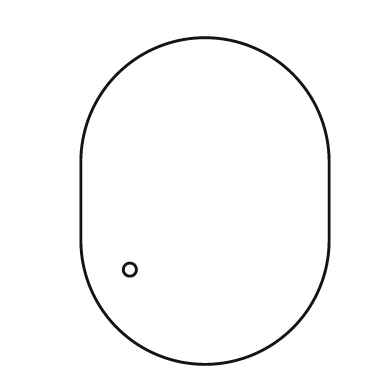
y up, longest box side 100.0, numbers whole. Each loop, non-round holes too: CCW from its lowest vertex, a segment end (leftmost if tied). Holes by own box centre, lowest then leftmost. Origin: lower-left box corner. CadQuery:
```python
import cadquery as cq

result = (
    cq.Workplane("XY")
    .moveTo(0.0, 38.0)
    .threePointArc((38.0, 0.0), (76.0, 38.0))
    .lineTo(76.0, 62.0)
    .threePointArc((38.0, 100.0), (0.0, 62.0))
    .close()
    .moveTo(15.0, 29.0)
    .circle(2.0)
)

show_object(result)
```